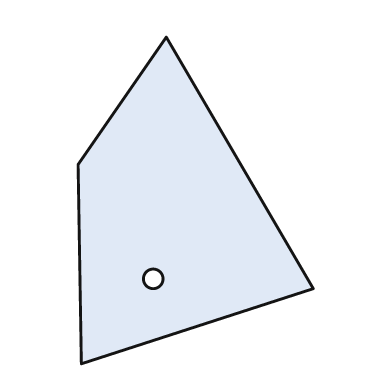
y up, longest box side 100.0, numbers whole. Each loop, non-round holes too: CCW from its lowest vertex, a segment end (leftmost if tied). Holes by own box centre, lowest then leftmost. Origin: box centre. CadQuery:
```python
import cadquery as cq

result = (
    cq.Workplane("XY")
    .moveTo(-35.0, -50.0)
    .lineTo(36.0, -27.0)
    .lineTo(-9.0, 50.0)
    .lineTo(-36.0, 11.0)
    .close()
    .moveTo(-13.0, -24.0)
    .circle(3.0)
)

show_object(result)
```